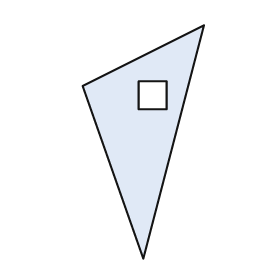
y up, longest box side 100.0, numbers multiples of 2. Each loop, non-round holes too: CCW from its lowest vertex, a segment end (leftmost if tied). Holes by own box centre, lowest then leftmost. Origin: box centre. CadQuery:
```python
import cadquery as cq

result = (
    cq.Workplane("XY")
    .moveTo(0.0, -50.0)
    .lineTo(26.0, 50.0)
    .lineTo(-26.0, 24.0)
    .close()
    .moveTo(-2.0, 14.0)
    .lineTo(10.0, 14.0)
    .lineTo(10.0, 26.0)
    .lineTo(-2.0, 26.0)
    .close()
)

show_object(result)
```